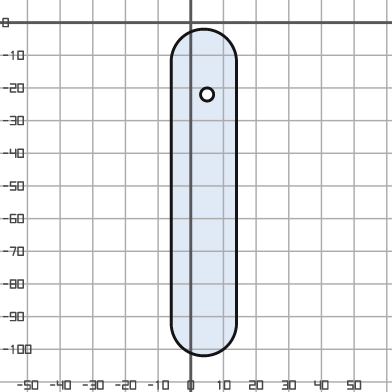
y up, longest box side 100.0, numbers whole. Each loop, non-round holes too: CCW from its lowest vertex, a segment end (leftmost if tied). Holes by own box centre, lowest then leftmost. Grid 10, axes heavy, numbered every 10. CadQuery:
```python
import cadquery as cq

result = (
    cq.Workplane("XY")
    .moveTo(-6.0, -92.0)
    .threePointArc((4.0, -102.0), (14.0, -92.0))
    .lineTo(14.0, -12.0)
    .threePointArc((4.0, -2.0), (-6.0, -12.0))
    .close()
    .moveTo(5.0, -22.0)
    .circle(2.0)
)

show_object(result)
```